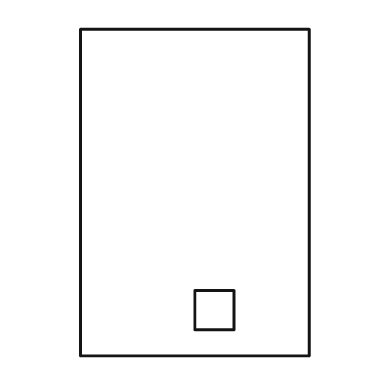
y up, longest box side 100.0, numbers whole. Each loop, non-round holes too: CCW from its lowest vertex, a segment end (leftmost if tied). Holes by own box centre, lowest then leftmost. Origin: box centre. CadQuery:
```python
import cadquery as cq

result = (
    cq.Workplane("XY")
    .moveTo(-35.0, -50.0)
    .lineTo(35.0, -50.0)
    .lineTo(35.0, 50.0)
    .lineTo(-35.0, 50.0)
    .close()
    .moveTo(0.0, -42.0)
    .lineTo(12.0, -42.0)
    .lineTo(12.0, -30.0)
    .lineTo(0.0, -30.0)
    .close()
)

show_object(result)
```